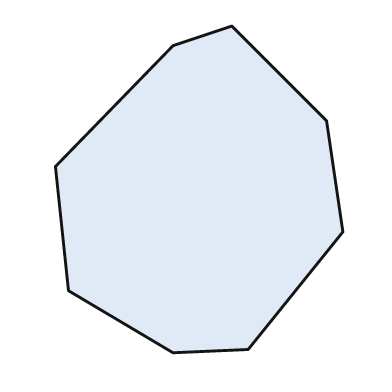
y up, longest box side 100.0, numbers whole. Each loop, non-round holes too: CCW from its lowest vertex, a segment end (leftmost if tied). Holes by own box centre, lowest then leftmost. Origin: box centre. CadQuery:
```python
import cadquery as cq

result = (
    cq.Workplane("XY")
    .moveTo(-8.0, -50.0)
    .lineTo(15.0, -49.0)
    .lineTo(44.0, -13.0)
    .lineTo(39.0, 21.0)
    .lineTo(10.0, 50.0)
    .lineTo(-8.0, 44.0)
    .lineTo(-44.0, 7.0)
    .lineTo(-40.0, -31.0)
    .close()
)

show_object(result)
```